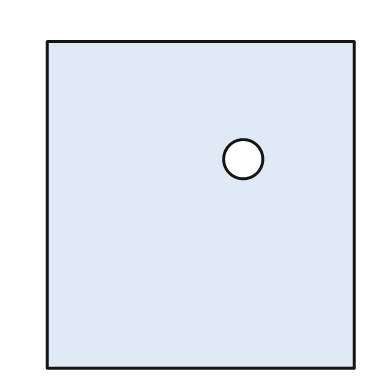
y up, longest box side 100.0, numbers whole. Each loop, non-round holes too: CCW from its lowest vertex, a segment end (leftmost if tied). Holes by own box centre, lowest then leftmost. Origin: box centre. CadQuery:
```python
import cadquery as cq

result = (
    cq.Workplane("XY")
    .moveTo(-47.0, -50.0)
    .lineTo(47.0, -50.0)
    .lineTo(47.0, 50.0)
    .lineTo(-47.0, 50.0)
    .close()
    .moveTo(13.0, 14.0)
    .circle(6.0)
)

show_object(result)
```